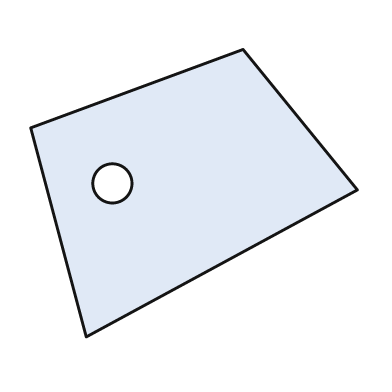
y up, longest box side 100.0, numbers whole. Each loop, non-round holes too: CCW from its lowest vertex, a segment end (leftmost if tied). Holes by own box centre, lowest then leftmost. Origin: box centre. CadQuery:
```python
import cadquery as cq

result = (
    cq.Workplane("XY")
    .moveTo(-33.0, -44.0)
    .lineTo(50.0, 1.0)
    .lineTo(15.0, 44.0)
    .lineTo(-50.0, 20.0)
    .close()
    .moveTo(-25.0, 3.0)
    .circle(6.0)
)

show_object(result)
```